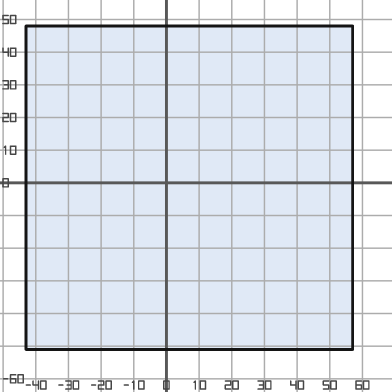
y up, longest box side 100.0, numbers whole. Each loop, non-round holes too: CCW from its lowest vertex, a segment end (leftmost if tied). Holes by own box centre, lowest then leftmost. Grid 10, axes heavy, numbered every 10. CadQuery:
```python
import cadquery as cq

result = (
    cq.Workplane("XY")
    .moveTo(-43.0, -51.0)
    .lineTo(57.0, -51.0)
    .lineTo(57.0, 48.0)
    .lineTo(-43.0, 48.0)
    .close()
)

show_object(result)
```